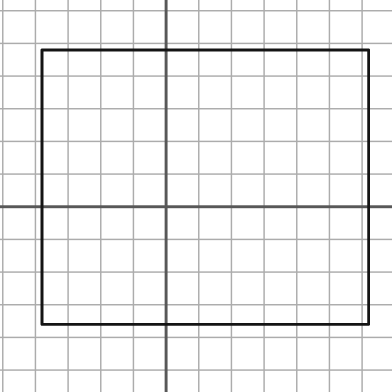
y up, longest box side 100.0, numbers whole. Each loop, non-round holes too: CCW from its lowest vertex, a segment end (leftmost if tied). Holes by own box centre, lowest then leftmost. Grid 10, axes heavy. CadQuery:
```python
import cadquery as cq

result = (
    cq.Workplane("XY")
    .moveTo(-38.0, -36.0)
    .lineTo(62.0, -36.0)
    .lineTo(62.0, 48.0)
    .lineTo(-38.0, 48.0)
    .close()
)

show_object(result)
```